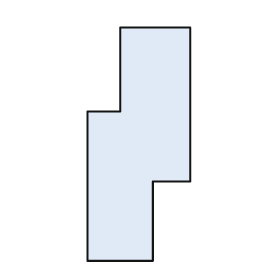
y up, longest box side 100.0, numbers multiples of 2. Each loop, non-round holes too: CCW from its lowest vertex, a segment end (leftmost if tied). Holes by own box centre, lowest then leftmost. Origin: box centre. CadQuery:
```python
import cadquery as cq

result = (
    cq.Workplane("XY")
    .moveTo(-22.0, -50.0)
    .lineTo(6.0, -50.0)
    .lineTo(6.0, -16.0)
    .lineTo(22.0, -16.0)
    .lineTo(22.0, 50.0)
    .lineTo(-8.0, 50.0)
    .lineTo(-8.0, 14.0)
    .lineTo(-22.0, 14.0)
    .close()
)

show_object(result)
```